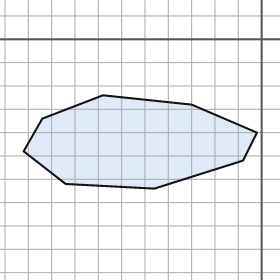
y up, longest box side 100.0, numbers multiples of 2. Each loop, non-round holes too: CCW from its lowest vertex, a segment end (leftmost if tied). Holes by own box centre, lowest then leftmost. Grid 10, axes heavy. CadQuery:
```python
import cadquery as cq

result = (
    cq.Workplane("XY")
    .moveTo(-46.0, -64.0)
    .lineTo(-8.0, -52.0)
    .lineTo(-2.0, -40.0)
    .lineTo(-30.0, -28.0)
    .lineTo(-68.0, -24.0)
    .lineTo(-94.0, -34.0)
    .lineTo(-102.0, -48.0)
    .lineTo(-84.0, -62.0)
    .close()
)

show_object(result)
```